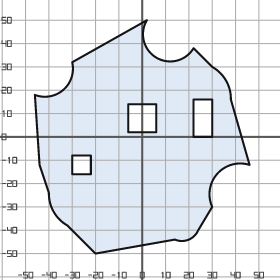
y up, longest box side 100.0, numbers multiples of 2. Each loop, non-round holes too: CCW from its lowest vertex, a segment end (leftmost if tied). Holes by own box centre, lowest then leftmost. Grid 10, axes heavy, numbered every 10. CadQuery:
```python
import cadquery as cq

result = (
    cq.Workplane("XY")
    .moveTo(-20.0, -50.0)
    .lineTo(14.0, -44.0)
    .threePointArc((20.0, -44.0), (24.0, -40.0))
    .lineTo(30.0, -30.0)
    .threePointArc((32.0, -16.0), (46.0, -12.0))
    .lineTo(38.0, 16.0)
    .threePointArc((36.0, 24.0), (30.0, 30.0))
    .lineTo(22.0, 38.0)
    .threePointArc((6.0, 34.0), (2.0, 50.0))
    .lineTo(-30.0, 32.0)
    .threePointArc((-34.0, 20.0), (-46.0, 18.0))
    .lineTo(-44.0, -12.0)
    .lineTo(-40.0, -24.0)
    .threePointArc((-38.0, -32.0), (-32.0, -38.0))
    .close()
    .moveTo(-30.0, -16.0)
    .lineTo(-22.0, -16.0)
    .lineTo(-22.0, -8.0)
    .lineTo(-30.0, -8.0)
    .close()
    .moveTo(-6.0, 2.0)
    .lineTo(6.0, 2.0)
    .lineTo(6.0, 14.0)
    .lineTo(-6.0, 14.0)
    .close()
    .moveTo(22.0, 0.0)
    .lineTo(30.0, 0.0)
    .lineTo(30.0, 16.0)
    .lineTo(22.0, 16.0)
    .close()
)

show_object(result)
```